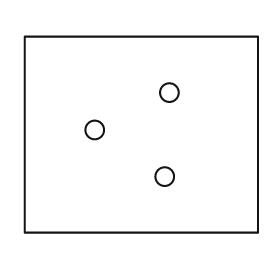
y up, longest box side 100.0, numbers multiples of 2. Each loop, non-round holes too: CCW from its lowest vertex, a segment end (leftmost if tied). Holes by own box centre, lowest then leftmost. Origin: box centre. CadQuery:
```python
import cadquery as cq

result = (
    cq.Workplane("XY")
    .moveTo(-50.0, -42.0)
    .lineTo(50.0, -42.0)
    .lineTo(50.0, 42.0)
    .lineTo(-50.0, 42.0)
    .close()
    .moveTo(10.0, -18.0)
    .circle(4.0)
    .moveTo(-20.0, 2.0)
    .circle(4.0)
    .moveTo(12.0, 18.0)
    .circle(4.0)
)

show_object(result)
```